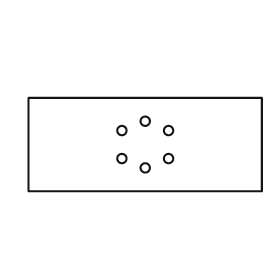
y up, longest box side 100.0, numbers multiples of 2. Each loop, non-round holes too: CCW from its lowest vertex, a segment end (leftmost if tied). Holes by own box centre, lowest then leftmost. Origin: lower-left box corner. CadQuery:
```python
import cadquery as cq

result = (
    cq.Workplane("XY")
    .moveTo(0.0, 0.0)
    .lineTo(100.0, 0.0)
    .lineTo(100.0, 40.0)
    .lineTo(0.0, 40.0)
    .close()
    .moveTo(50.0, 10.0)
    .circle(2.0)
    .moveTo(40.0, 14.0)
    .circle(2.0)
    .moveTo(60.0, 14.0)
    .circle(2.0)
    .moveTo(40.0, 26.0)
    .circle(2.0)
    .moveTo(60.0, 26.0)
    .circle(2.0)
    .moveTo(50.0, 30.0)
    .circle(2.0)
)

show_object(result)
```